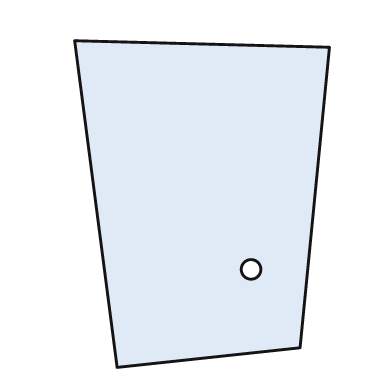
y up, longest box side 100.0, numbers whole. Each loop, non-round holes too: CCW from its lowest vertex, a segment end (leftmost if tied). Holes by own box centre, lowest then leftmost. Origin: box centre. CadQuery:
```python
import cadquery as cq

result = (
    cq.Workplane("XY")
    .moveTo(-26.0, -50.0)
    .lineTo(30.0, -44.0)
    .lineTo(39.0, 48.0)
    .lineTo(-39.0, 50.0)
    .close()
    .moveTo(15.0, -20.0)
    .circle(3.0)
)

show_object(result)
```